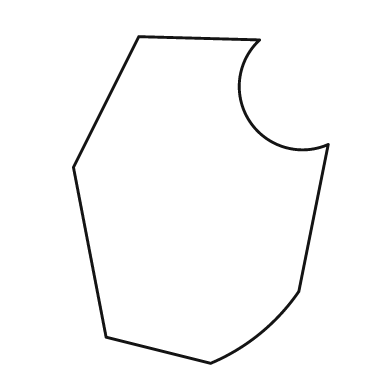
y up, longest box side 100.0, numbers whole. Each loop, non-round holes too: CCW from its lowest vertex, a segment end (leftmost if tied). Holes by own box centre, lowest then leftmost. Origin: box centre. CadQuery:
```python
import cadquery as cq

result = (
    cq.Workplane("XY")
    .moveTo(3.0, -50.0)
    .threePointArc((18.0, -41.0), (30.0, -28.0))
    .lineTo(39.0, 17.0)
    .threePointArc((15.0, 24.0), (18.0, 49.0))
    .lineTo(-19.0, 50.0)
    .lineTo(-39.0, 10.0)
    .lineTo(-29.0, -42.0)
    .close()
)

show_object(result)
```